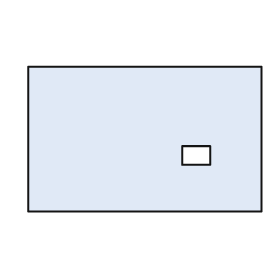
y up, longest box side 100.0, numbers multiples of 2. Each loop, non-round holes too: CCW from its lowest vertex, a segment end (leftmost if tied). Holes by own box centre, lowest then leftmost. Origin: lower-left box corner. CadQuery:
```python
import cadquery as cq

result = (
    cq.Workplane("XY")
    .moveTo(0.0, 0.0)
    .lineTo(100.0, 0.0)
    .lineTo(100.0, 62.0)
    .lineTo(0.0, 62.0)
    .close()
    .moveTo(66.0, 20.0)
    .lineTo(78.0, 20.0)
    .lineTo(78.0, 28.0)
    .lineTo(66.0, 28.0)
    .close()
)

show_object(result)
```